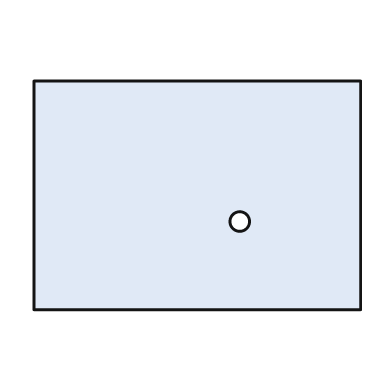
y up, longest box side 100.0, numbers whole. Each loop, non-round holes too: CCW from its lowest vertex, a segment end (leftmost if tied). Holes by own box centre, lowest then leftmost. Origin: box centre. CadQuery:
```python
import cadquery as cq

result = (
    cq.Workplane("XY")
    .moveTo(-50.0, -35.0)
    .lineTo(50.0, -35.0)
    .lineTo(50.0, 35.0)
    .lineTo(-50.0, 35.0)
    .close()
    .moveTo(13.0, -8.0)
    .circle(3.0)
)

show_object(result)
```